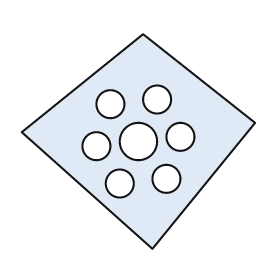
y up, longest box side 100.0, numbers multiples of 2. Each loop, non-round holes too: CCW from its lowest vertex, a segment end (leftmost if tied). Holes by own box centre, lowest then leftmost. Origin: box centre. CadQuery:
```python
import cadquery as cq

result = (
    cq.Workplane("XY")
    .moveTo(6.0, -46.0)
    .lineTo(50.0, 8.0)
    .lineTo(2.0, 46.0)
    .lineTo(-50.0, 4.0)
    .close()
    .moveTo(-8.0, -18.0)
    .circle(6.0)
    .moveTo(12.0, -16.0)
    .circle(6.0)
    .moveTo(-18.0, -2.0)
    .circle(6.0)
    .moveTo(0.0, 0.0)
    .circle(8.0)
    .moveTo(18.0, 2.0)
    .circle(6.0)
    .moveTo(-12.0, 16.0)
    .circle(6.0)
    .moveTo(8.0, 18.0)
    .circle(6.0)
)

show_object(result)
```